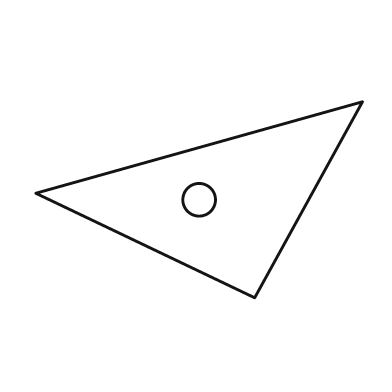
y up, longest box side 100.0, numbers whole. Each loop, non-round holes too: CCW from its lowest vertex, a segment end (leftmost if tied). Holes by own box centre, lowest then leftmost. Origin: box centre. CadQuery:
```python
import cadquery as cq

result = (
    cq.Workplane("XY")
    .moveTo(17.0, -30.0)
    .lineTo(50.0, 30.0)
    .lineTo(-50.0, 2.0)
    .close()
    .moveTo(0.0, 0.0)
    .circle(5.0)
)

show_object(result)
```